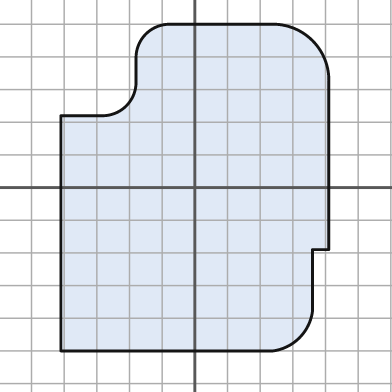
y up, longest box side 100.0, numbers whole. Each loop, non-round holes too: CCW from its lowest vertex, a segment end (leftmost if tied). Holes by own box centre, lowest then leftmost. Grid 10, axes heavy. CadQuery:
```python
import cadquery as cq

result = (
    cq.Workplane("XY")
    .moveTo(-41.0, -50.0)
    .lineTo(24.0, -50.0)
    .threePointArc((32.0, -46.0), (36.0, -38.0))
    .lineTo(36.0, -19.0)
    .lineTo(41.0, -19.0)
    .lineTo(41.0, 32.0)
    .threePointArc((36.0, 45.0), (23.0, 50.0))
    .lineTo(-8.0, 50.0)
    .threePointArc((-15.0, 47.0), (-18.0, 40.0))
    .lineTo(-18.0, 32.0)
    .threePointArc((-21.0, 25.0), (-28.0, 22.0))
    .lineTo(-41.0, 22.0)
    .close()
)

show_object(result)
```